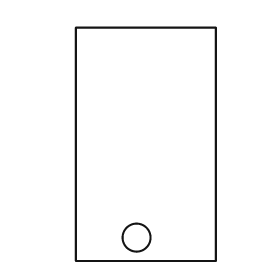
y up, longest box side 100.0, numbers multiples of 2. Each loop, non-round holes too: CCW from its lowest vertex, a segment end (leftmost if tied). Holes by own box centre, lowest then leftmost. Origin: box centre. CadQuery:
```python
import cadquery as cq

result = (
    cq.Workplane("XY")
    .moveTo(-30.0, -50.0)
    .lineTo(30.0, -50.0)
    .lineTo(30.0, 50.0)
    .lineTo(-30.0, 50.0)
    .close()
    .moveTo(-4.0, -40.0)
    .circle(6.0)
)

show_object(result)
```